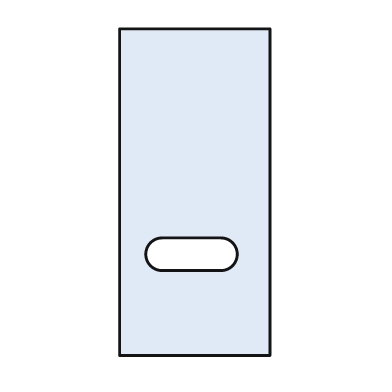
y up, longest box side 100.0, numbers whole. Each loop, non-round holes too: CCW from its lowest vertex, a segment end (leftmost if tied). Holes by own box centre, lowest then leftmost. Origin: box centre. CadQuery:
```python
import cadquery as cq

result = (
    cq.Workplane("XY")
    .moveTo(-23.0, -50.0)
    .lineTo(23.0, -50.0)
    .lineTo(23.0, 50.0)
    .lineTo(-23.0, 50.0)
    .close()
    .moveTo(-10.0, -24.0)
    .lineTo(8.0, -24.0)
    .threePointArc((13.0, -19.0), (8.0, -14.0))
    .lineTo(-10.0, -14.0)
    .threePointArc((-15.0, -19.0), (-10.0, -24.0))
    .close()
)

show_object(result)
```